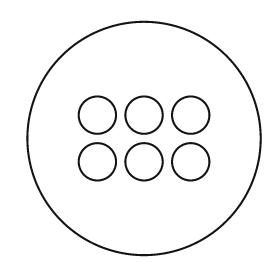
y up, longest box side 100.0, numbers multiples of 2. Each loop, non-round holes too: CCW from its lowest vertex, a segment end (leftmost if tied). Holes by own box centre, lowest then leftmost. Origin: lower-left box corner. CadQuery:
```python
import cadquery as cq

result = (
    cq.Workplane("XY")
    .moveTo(50.0, 50.0)
    .circle(50.0)
    .moveTo(30.0, 40.0)
    .circle(8.0)
    .moveTo(50.0, 40.0)
    .circle(8.0)
    .moveTo(70.0, 40.0)
    .circle(8.0)
    .moveTo(30.0, 60.0)
    .circle(8.0)
    .moveTo(50.0, 60.0)
    .circle(8.0)
    .moveTo(70.0, 60.0)
    .circle(8.0)
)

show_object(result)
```